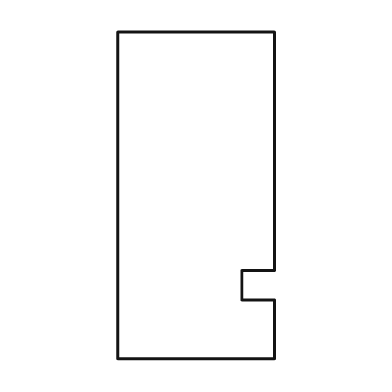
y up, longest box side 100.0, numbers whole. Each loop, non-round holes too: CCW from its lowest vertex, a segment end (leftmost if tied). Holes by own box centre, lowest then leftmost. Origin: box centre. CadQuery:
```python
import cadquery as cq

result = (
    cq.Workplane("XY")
    .moveTo(-24.0, -50.0)
    .lineTo(24.0, -50.0)
    .lineTo(24.0, -32.0)
    .lineTo(14.0, -32.0)
    .lineTo(14.0, -23.0)
    .lineTo(24.0, -23.0)
    .lineTo(24.0, 50.0)
    .lineTo(-24.0, 50.0)
    .close()
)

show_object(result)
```